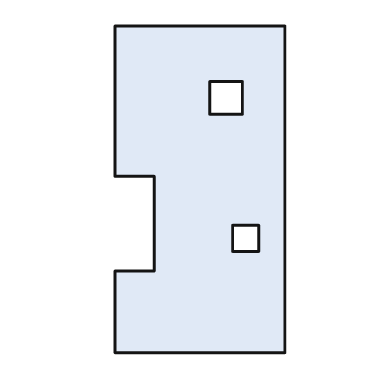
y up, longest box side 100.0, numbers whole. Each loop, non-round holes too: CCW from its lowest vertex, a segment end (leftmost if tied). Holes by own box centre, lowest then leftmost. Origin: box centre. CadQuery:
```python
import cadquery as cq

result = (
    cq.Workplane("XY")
    .moveTo(-26.0, -50.0)
    .lineTo(26.0, -50.0)
    .lineTo(26.0, 50.0)
    .lineTo(-26.0, 50.0)
    .lineTo(-26.0, 4.0)
    .lineTo(-14.0, 4.0)
    .lineTo(-14.0, -25.0)
    .lineTo(-26.0, -25.0)
    .close()
    .moveTo(10.0, -19.0)
    .lineTo(18.0, -19.0)
    .lineTo(18.0, -11.0)
    .lineTo(10.0, -11.0)
    .close()
    .moveTo(3.0, 23.0)
    .lineTo(13.0, 23.0)
    .lineTo(13.0, 33.0)
    .lineTo(3.0, 33.0)
    .close()
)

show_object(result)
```